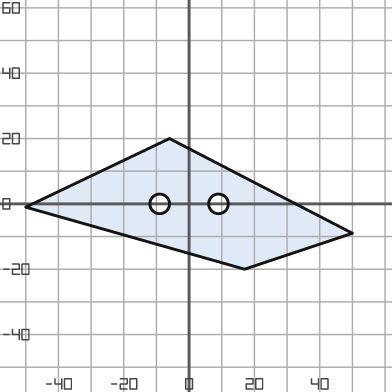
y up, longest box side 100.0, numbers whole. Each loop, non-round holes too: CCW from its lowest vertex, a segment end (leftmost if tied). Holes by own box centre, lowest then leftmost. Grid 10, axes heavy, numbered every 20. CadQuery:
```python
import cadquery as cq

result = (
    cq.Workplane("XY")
    .moveTo(17.0, -20.0)
    .lineTo(50.0, -9.0)
    .lineTo(-6.0, 20.0)
    .lineTo(-50.0, -1.0)
    .close()
    .moveTo(-9.0, 0.0)
    .circle(3.0)
    .moveTo(9.0, 0.0)
    .circle(3.0)
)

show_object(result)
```